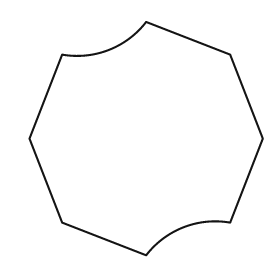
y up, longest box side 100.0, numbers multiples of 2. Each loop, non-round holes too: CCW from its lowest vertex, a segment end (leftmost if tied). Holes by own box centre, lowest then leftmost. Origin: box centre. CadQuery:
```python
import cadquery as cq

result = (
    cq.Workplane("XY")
    .moveTo(0.0, -50.0)
    .threePointArc((16.0, -38.0), (36.0, -36.0))
    .lineTo(50.0, 0.0)
    .lineTo(36.0, 36.0)
    .lineTo(0.0, 50.0)
    .threePointArc((-16.0, 38.0), (-36.0, 36.0))
    .lineTo(-50.0, 0.0)
    .lineTo(-36.0, -36.0)
    .close()
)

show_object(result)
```